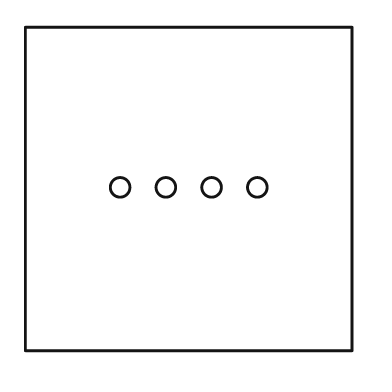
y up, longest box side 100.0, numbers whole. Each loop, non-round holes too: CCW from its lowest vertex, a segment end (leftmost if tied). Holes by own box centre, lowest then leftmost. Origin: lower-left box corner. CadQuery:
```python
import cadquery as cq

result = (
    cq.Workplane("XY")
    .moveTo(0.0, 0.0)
    .lineTo(100.0, 0.0)
    .lineTo(100.0, 99.0)
    .lineTo(0.0, 99.0)
    .close()
    .moveTo(29.0, 50.0)
    .circle(3.0)
    .moveTo(43.0, 50.0)
    .circle(3.0)
    .moveTo(57.0, 50.0)
    .circle(3.0)
    .moveTo(71.0, 50.0)
    .circle(3.0)
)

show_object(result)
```